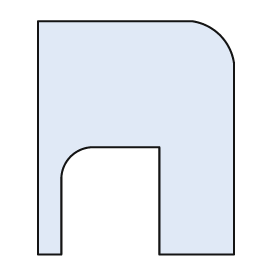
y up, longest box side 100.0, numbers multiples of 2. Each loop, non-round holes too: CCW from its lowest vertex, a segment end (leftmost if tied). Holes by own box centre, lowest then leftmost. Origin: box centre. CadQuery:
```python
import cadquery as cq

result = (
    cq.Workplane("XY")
    .moveTo(-42.0, -50.0)
    .lineTo(-32.0, -50.0)
    .lineTo(-32.0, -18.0)
    .threePointArc((-28.0, -8.0), (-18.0, -4.0))
    .lineTo(10.0, -4.0)
    .lineTo(10.0, -50.0)
    .lineTo(42.0, -50.0)
    .lineTo(42.0, 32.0)
    .threePointArc((36.0, 44.0), (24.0, 50.0))
    .lineTo(-42.0, 50.0)
    .close()
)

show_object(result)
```